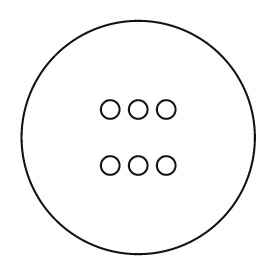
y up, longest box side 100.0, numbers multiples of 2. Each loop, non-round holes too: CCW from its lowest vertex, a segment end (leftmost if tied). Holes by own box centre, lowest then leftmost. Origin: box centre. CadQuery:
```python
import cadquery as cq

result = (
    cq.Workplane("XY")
    .moveTo(0.0, 0.0)
    .circle(50.0)
    .moveTo(-12.0, -12.0)
    .circle(4.0)
    .moveTo(0.0, -12.0)
    .circle(4.0)
    .moveTo(12.0, -12.0)
    .circle(4.0)
    .moveTo(-12.0, 12.0)
    .circle(4.0)
    .moveTo(0.0, 12.0)
    .circle(4.0)
    .moveTo(12.0, 12.0)
    .circle(4.0)
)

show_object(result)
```